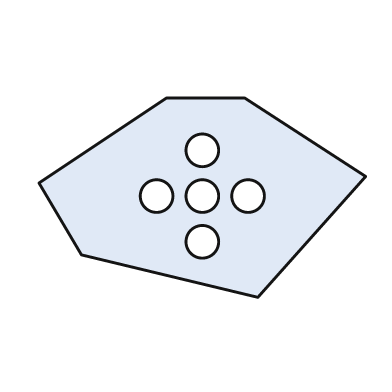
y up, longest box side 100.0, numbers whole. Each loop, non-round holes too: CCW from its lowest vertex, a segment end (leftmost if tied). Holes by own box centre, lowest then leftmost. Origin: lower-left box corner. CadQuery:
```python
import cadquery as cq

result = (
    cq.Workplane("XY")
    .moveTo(67.0, 0.0)
    .lineTo(100.0, 37.0)
    .lineTo(63.0, 61.0)
    .lineTo(39.0, 61.0)
    .lineTo(0.0, 35.0)
    .lineTo(13.0, 13.0)
    .close()
    .moveTo(50.0, 17.0)
    .circle(5.0)
    .moveTo(36.0, 31.0)
    .circle(5.0)
    .moveTo(50.0, 31.0)
    .circle(5.0)
    .moveTo(64.0, 31.0)
    .circle(5.0)
    .moveTo(50.0, 45.0)
    .circle(5.0)
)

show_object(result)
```